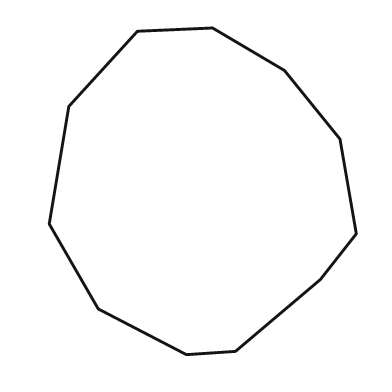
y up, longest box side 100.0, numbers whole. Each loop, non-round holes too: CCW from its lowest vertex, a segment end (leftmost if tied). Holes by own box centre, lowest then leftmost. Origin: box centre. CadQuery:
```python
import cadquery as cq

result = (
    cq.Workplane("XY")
    .moveTo(-5.0, -50.0)
    .lineTo(10.0, -49.0)
    .lineTo(36.0, -27.0)
    .lineTo(47.0, -13.0)
    .lineTo(42.0, 16.0)
    .lineTo(25.0, 37.0)
    .lineTo(3.0, 50.0)
    .lineTo(-20.0, 49.0)
    .lineTo(-41.0, 26.0)
    .lineTo(-47.0, -10.0)
    .lineTo(-32.0, -36.0)
    .close()
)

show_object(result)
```